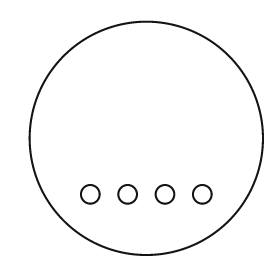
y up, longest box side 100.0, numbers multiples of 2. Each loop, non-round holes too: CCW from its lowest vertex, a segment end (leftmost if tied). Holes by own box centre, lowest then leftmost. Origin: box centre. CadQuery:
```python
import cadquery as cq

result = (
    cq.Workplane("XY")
    .moveTo(0.0, 0.0)
    .circle(50.0)
    .moveTo(-24.0, -24.0)
    .circle(4.0)
    .moveTo(-8.0, -24.0)
    .circle(4.0)
    .moveTo(8.0, -24.0)
    .circle(4.0)
    .moveTo(24.0, -24.0)
    .circle(4.0)
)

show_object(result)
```